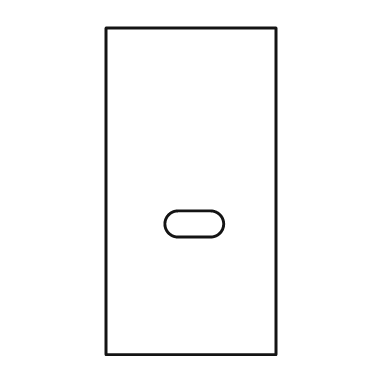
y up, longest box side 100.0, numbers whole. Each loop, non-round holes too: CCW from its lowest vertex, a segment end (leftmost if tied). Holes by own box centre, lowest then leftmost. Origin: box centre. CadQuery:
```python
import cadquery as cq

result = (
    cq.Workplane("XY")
    .moveTo(-26.0, -50.0)
    .lineTo(26.0, -50.0)
    .lineTo(26.0, 50.0)
    .lineTo(-26.0, 50.0)
    .close()
    .moveTo(-4.0, -14.0)
    .lineTo(6.0, -14.0)
    .threePointArc((10.0, -10.0), (6.0, -6.0))
    .lineTo(-4.0, -6.0)
    .threePointArc((-8.0, -10.0), (-4.0, -14.0))
    .close()
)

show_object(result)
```